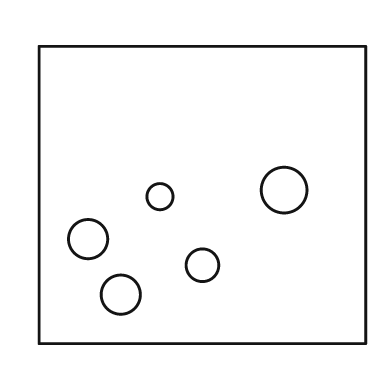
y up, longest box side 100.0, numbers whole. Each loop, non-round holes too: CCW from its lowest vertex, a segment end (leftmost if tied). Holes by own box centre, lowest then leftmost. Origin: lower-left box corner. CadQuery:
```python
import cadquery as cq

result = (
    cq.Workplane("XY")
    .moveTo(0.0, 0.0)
    .lineTo(100.0, 0.0)
    .lineTo(100.0, 91.0)
    .lineTo(0.0, 91.0)
    .close()
    .moveTo(25.0, 15.0)
    .circle(6.0)
    .moveTo(50.0, 24.0)
    .circle(5.0)
    .moveTo(15.0, 32.0)
    .circle(6.0)
    .moveTo(37.0, 45.0)
    .circle(4.0)
    .moveTo(75.0, 47.0)
    .circle(7.0)
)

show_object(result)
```